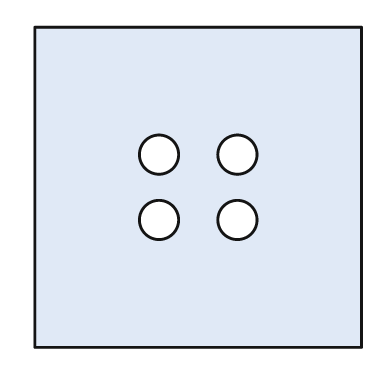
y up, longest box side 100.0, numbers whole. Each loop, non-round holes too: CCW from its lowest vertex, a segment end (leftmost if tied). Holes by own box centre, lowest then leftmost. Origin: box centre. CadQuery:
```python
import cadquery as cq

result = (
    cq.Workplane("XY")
    .moveTo(-50.0, -49.0)
    .lineTo(50.0, -49.0)
    .lineTo(50.0, 49.0)
    .lineTo(-50.0, 49.0)
    .close()
    .moveTo(-12.0, -10.0)
    .circle(6.0)
    .moveTo(12.0, -10.0)
    .circle(6.0)
    .moveTo(-12.0, 10.0)
    .circle(6.0)
    .moveTo(12.0, 10.0)
    .circle(6.0)
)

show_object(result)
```